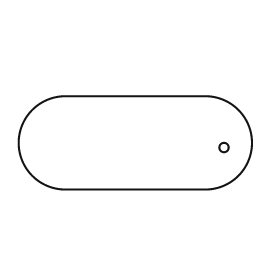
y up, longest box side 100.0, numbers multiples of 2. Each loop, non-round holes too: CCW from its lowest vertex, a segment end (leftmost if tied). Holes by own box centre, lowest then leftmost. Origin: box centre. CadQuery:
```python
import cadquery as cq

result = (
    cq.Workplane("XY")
    .moveTo(-30.0, -20.0)
    .lineTo(30.0, -20.0)
    .threePointArc((50.0, 0.0), (30.0, 20.0))
    .lineTo(-30.0, 20.0)
    .threePointArc((-50.0, 0.0), (-30.0, -20.0))
    .close()
    .moveTo(38.0, -2.0)
    .circle(2.0)
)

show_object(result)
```